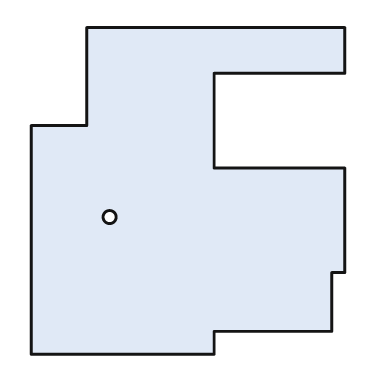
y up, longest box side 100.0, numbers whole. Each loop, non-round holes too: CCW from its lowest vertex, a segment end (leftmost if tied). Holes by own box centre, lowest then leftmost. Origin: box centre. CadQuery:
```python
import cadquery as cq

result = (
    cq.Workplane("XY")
    .moveTo(-48.0, -50.0)
    .lineTo(8.0, -50.0)
    .lineTo(8.0, -43.0)
    .lineTo(44.0, -43.0)
    .lineTo(44.0, -25.0)
    .lineTo(48.0, -25.0)
    .lineTo(48.0, 7.0)
    .lineTo(8.0, 7.0)
    .lineTo(8.0, 36.0)
    .lineTo(48.0, 36.0)
    .lineTo(48.0, 50.0)
    .lineTo(-31.0, 50.0)
    .lineTo(-31.0, 20.0)
    .lineTo(-48.0, 20.0)
    .close()
    .moveTo(-24.0, -8.0)
    .circle(2.0)
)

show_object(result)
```